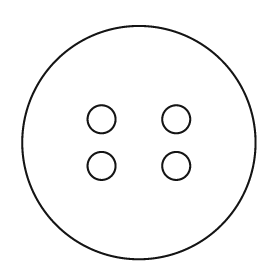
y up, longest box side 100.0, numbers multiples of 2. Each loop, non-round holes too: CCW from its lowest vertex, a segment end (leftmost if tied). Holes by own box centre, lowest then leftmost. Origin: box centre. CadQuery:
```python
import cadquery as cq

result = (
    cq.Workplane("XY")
    .moveTo(0.0, 0.0)
    .circle(50.0)
    .moveTo(-16.0, -10.0)
    .circle(6.0)
    .moveTo(16.0, -10.0)
    .circle(6.0)
    .moveTo(-16.0, 10.0)
    .circle(6.0)
    .moveTo(16.0, 10.0)
    .circle(6.0)
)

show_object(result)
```